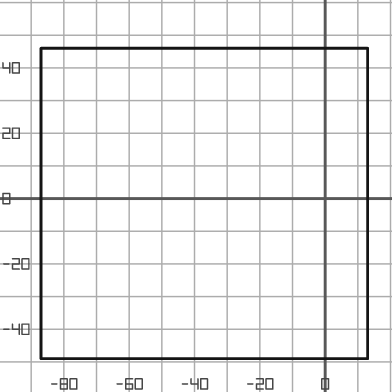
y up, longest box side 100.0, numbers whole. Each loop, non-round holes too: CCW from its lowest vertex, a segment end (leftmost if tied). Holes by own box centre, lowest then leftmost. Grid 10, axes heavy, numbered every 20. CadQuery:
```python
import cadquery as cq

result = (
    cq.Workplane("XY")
    .moveTo(-87.0, -49.0)
    .lineTo(13.0, -49.0)
    .lineTo(13.0, 46.0)
    .lineTo(-87.0, 46.0)
    .close()
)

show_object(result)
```